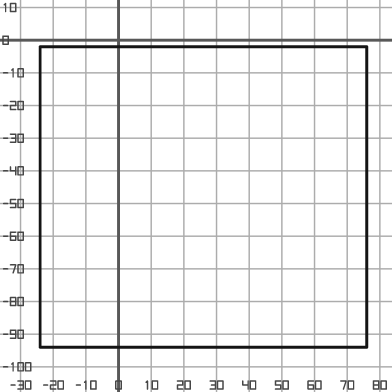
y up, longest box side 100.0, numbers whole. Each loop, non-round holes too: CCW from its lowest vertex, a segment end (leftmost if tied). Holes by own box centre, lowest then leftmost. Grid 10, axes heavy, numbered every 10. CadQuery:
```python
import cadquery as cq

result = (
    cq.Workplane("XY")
    .moveTo(-24.0, -94.0)
    .lineTo(76.0, -94.0)
    .lineTo(76.0, -2.0)
    .lineTo(-24.0, -2.0)
    .close()
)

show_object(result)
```